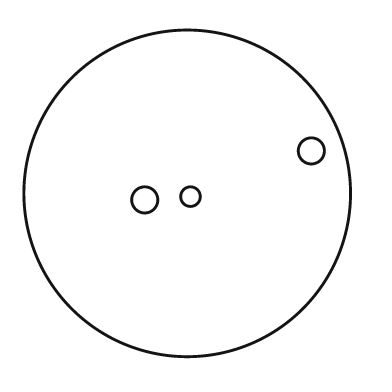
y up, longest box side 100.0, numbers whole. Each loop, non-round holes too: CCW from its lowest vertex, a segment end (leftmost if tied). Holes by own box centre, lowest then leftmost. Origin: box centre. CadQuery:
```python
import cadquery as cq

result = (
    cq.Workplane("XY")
    .moveTo(0.0, 0.0)
    .circle(50.0)
    .moveTo(-13.0, -2.0)
    .circle(4.0)
    .moveTo(1.0, -1.0)
    .circle(3.0)
    .moveTo(38.0, 13.0)
    .circle(4.0)
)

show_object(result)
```